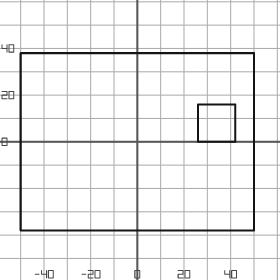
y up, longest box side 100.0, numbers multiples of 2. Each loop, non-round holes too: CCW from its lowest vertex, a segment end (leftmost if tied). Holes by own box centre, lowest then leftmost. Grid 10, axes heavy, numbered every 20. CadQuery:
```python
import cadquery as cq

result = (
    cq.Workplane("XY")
    .moveTo(-50.0, -38.0)
    .lineTo(50.0, -38.0)
    .lineTo(50.0, 38.0)
    .lineTo(-50.0, 38.0)
    .close()
    .moveTo(26.0, 0.0)
    .lineTo(42.0, 0.0)
    .lineTo(42.0, 16.0)
    .lineTo(26.0, 16.0)
    .close()
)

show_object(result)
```